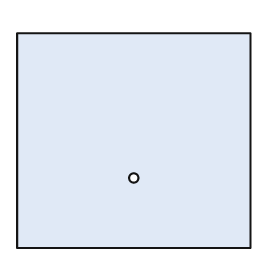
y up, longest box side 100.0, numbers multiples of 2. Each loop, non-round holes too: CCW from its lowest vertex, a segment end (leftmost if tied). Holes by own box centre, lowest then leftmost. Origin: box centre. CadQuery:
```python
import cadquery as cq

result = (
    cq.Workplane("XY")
    .moveTo(-50.0, -46.0)
    .lineTo(50.0, -46.0)
    .lineTo(50.0, 46.0)
    .lineTo(-50.0, 46.0)
    .close()
    .moveTo(0.0, -16.0)
    .circle(2.0)
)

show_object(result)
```